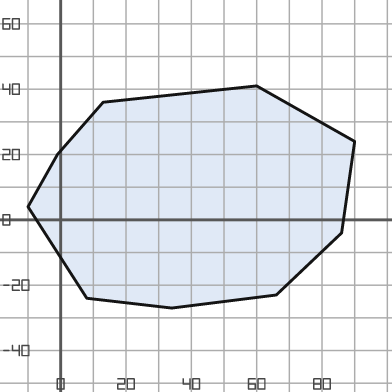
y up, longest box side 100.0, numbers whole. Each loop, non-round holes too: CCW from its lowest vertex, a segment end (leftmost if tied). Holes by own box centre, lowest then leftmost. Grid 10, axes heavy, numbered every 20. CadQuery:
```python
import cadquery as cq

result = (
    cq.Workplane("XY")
    .moveTo(34.0, -27.0)
    .lineTo(66.0, -23.0)
    .lineTo(86.0, -4.0)
    .lineTo(90.0, 24.0)
    .lineTo(60.0, 41.0)
    .lineTo(13.0, 36.0)
    .lineTo(-1.0, 20.0)
    .lineTo(-10.0, 4.0)
    .lineTo(8.0, -24.0)
    .close()
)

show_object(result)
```